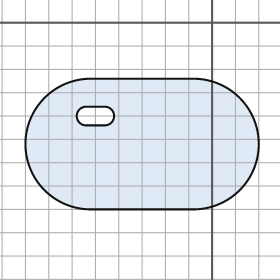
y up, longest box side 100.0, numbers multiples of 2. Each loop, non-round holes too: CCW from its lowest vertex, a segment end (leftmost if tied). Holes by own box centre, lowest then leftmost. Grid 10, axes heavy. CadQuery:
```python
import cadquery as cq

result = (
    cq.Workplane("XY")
    .moveTo(-52.0, -80.0)
    .lineTo(-8.0, -80.0)
    .threePointArc((20.0, -52.0), (-8.0, -24.0))
    .lineTo(-52.0, -24.0)
    .threePointArc((-80.0, -52.0), (-52.0, -80.0))
    .close()
    .moveTo(-54.0, -44.0)
    .lineTo(-46.0, -44.0)
    .threePointArc((-42.0, -40.0), (-46.0, -36.0))
    .lineTo(-54.0, -36.0)
    .threePointArc((-58.0, -40.0), (-54.0, -44.0))
    .close()
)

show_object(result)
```